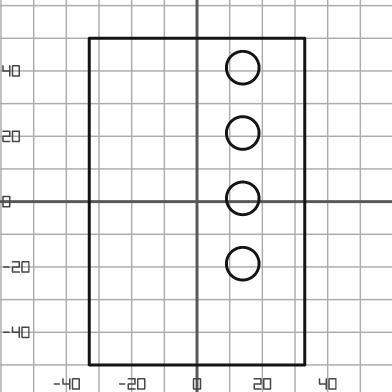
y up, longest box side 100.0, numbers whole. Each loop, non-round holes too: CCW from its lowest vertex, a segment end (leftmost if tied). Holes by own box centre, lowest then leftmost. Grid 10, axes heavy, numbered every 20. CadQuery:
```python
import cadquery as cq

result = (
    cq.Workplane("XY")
    .moveTo(-33.0, -50.0)
    .lineTo(33.0, -50.0)
    .lineTo(33.0, 50.0)
    .lineTo(-33.0, 50.0)
    .close()
    .moveTo(14.0, -19.0)
    .circle(5.0)
    .moveTo(14.0, 1.0)
    .circle(5.0)
    .moveTo(14.0, 21.0)
    .circle(5.0)
    .moveTo(14.0, 41.0)
    .circle(5.0)
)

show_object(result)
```